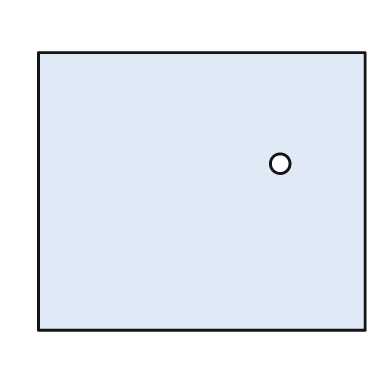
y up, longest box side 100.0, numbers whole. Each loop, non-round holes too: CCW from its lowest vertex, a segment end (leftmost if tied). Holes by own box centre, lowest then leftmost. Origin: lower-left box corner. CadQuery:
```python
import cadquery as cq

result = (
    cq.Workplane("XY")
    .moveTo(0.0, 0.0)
    .lineTo(100.0, 0.0)
    .lineTo(100.0, 85.0)
    .lineTo(0.0, 85.0)
    .close()
    .moveTo(74.0, 51.0)
    .circle(3.0)
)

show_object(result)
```